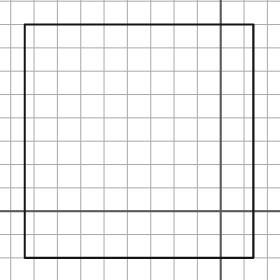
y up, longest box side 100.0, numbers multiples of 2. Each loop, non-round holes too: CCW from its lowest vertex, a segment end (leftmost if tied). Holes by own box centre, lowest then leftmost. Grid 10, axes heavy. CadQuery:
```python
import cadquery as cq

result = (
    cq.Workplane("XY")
    .moveTo(-84.0, -20.0)
    .lineTo(14.0, -20.0)
    .lineTo(14.0, 80.0)
    .lineTo(-84.0, 80.0)
    .close()
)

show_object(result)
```